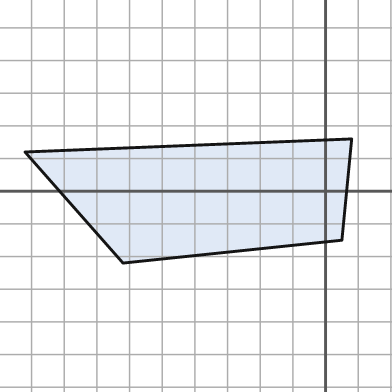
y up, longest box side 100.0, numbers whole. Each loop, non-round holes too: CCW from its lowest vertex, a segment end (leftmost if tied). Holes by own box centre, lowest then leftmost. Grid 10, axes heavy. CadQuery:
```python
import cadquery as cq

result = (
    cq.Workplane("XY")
    .moveTo(-62.0, -22.0)
    .lineTo(5.0, -15.0)
    .lineTo(8.0, 16.0)
    .lineTo(-92.0, 12.0)
    .close()
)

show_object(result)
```